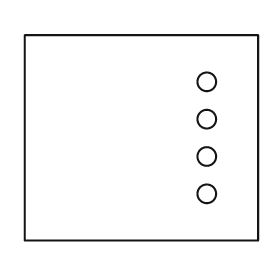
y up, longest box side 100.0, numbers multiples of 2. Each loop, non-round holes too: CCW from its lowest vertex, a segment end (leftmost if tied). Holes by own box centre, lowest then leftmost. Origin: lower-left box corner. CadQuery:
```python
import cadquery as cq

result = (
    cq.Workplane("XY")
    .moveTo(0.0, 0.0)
    .lineTo(100.0, 0.0)
    .lineTo(100.0, 88.0)
    .lineTo(0.0, 88.0)
    .close()
    .moveTo(78.0, 20.0)
    .circle(4.0)
    .moveTo(78.0, 36.0)
    .circle(4.0)
    .moveTo(78.0, 52.0)
    .circle(4.0)
    .moveTo(78.0, 68.0)
    .circle(4.0)
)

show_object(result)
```